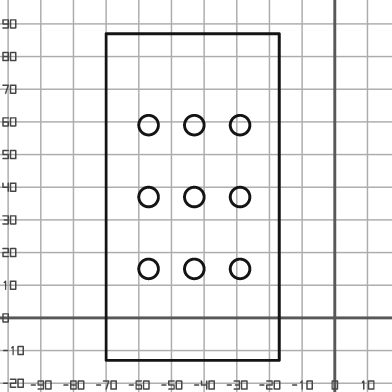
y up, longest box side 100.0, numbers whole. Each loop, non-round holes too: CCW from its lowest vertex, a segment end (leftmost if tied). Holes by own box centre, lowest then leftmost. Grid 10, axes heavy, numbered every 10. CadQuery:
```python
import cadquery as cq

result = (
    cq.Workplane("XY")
    .moveTo(-70.0, -13.0)
    .lineTo(-17.0, -13.0)
    .lineTo(-17.0, 87.0)
    .lineTo(-70.0, 87.0)
    .close()
    .moveTo(-57.0, 15.0)
    .circle(3.0)
    .moveTo(-43.0, 15.0)
    .circle(3.0)
    .moveTo(-29.0, 15.0)
    .circle(3.0)
    .moveTo(-57.0, 37.0)
    .circle(3.0)
    .moveTo(-43.0, 37.0)
    .circle(3.0)
    .moveTo(-29.0, 37.0)
    .circle(3.0)
    .moveTo(-57.0, 59.0)
    .circle(3.0)
    .moveTo(-43.0, 59.0)
    .circle(3.0)
    .moveTo(-29.0, 59.0)
    .circle(3.0)
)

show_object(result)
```